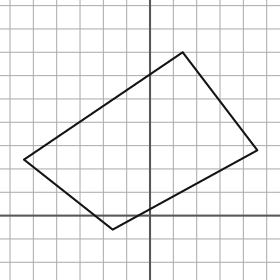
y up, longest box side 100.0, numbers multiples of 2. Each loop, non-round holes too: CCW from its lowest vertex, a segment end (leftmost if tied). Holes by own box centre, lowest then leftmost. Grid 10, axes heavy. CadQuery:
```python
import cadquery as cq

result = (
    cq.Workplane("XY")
    .moveTo(-16.0, -6.0)
    .lineTo(46.0, 28.0)
    .lineTo(14.0, 70.0)
    .lineTo(-54.0, 24.0)
    .close()
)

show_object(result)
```